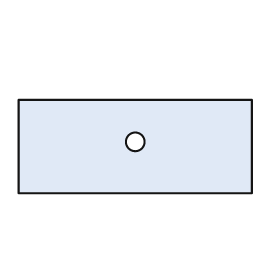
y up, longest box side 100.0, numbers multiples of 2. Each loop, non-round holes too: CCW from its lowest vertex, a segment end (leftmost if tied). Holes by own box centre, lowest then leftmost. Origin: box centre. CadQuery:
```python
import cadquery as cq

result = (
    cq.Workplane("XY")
    .moveTo(-50.0, -20.0)
    .lineTo(50.0, -20.0)
    .lineTo(50.0, 20.0)
    .lineTo(-50.0, 20.0)
    .close()
    .moveTo(0.0, 2.0)
    .circle(4.0)
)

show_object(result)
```